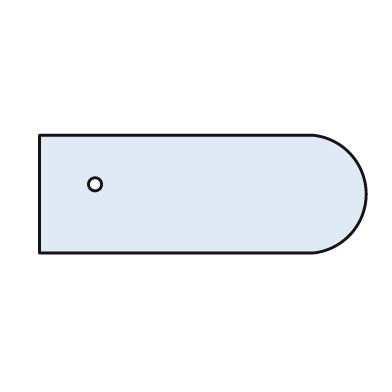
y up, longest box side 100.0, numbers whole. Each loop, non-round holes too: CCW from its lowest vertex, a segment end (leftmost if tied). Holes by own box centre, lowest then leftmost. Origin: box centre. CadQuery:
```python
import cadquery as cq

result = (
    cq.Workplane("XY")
    .moveTo(-50.0, -18.0)
    .lineTo(34.0, -18.0)
    .threePointArc((50.0, 0.0), (34.0, 18.0))
    .lineTo(-50.0, 18.0)
    .close()
    .moveTo(-33.0, 3.0)
    .circle(2.0)
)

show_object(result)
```